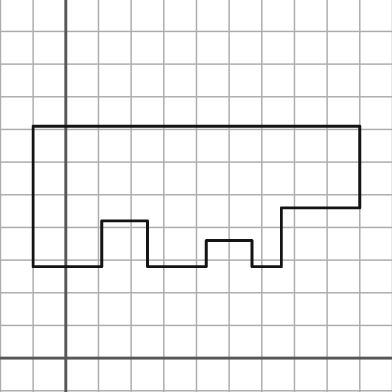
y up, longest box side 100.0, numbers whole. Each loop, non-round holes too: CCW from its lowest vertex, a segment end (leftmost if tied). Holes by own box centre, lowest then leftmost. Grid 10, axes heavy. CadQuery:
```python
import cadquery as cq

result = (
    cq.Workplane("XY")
    .moveTo(-10.0, 28.0)
    .lineTo(11.0, 28.0)
    .lineTo(11.0, 42.0)
    .lineTo(25.0, 42.0)
    .lineTo(25.0, 28.0)
    .lineTo(43.0, 28.0)
    .lineTo(43.0, 36.0)
    .lineTo(57.0, 36.0)
    .lineTo(57.0, 28.0)
    .lineTo(66.0, 28.0)
    .lineTo(66.0, 46.0)
    .lineTo(90.0, 46.0)
    .lineTo(90.0, 71.0)
    .lineTo(-10.0, 71.0)
    .close()
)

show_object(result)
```